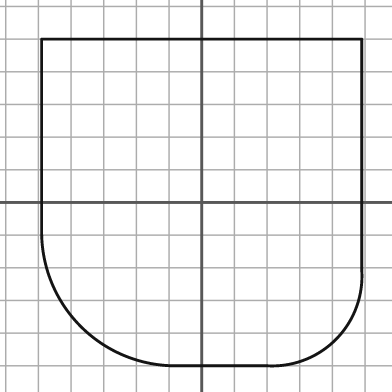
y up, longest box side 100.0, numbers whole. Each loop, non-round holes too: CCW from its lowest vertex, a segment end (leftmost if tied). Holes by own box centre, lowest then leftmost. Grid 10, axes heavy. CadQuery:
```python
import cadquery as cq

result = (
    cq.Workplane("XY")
    .moveTo(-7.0, -50.0)
    .lineTo(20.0, -50.0)
    .threePointArc((41.0, -42.0), (49.0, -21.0))
    .lineTo(49.0, 50.0)
    .lineTo(-49.0, 50.0)
    .lineTo(-49.0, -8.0)
    .threePointArc((-37.0, -38.0), (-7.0, -50.0))
    .close()
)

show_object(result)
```